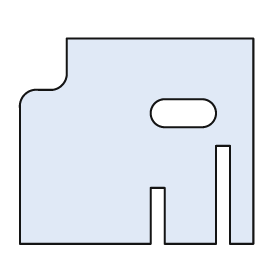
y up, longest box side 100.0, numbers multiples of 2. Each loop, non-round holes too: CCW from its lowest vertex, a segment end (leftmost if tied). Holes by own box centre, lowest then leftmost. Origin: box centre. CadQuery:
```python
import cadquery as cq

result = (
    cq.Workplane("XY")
    .moveTo(-50.0, -44.0)
    .lineTo(6.0, -44.0)
    .lineTo(6.0, -20.0)
    .lineTo(12.0, -20.0)
    .lineTo(12.0, -44.0)
    .lineTo(34.0, -44.0)
    .lineTo(34.0, -2.0)
    .lineTo(40.0, -2.0)
    .lineTo(40.0, -44.0)
    .lineTo(50.0, -44.0)
    .lineTo(50.0, 44.0)
    .lineTo(-30.0, 44.0)
    .lineTo(-30.0, 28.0)
    .threePointArc((-32.0, 24.0), (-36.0, 22.0))
    .lineTo(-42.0, 22.0)
    .threePointArc((-48.0, 20.0), (-50.0, 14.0))
    .close()
    .moveTo(12.0, 6.0)
    .lineTo(28.0, 6.0)
    .threePointArc((34.0, 12.0), (28.0, 18.0))
    .lineTo(12.0, 18.0)
    .threePointArc((6.0, 12.0), (12.0, 6.0))
    .close()
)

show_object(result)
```